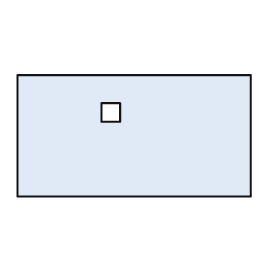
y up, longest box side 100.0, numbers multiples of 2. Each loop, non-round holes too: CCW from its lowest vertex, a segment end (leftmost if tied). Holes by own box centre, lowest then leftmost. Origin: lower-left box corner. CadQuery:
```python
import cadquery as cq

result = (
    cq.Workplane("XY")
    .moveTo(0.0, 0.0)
    .lineTo(100.0, 0.0)
    .lineTo(100.0, 52.0)
    .lineTo(0.0, 52.0)
    .close()
    .moveTo(36.0, 32.0)
    .lineTo(44.0, 32.0)
    .lineTo(44.0, 40.0)
    .lineTo(36.0, 40.0)
    .close()
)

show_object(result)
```